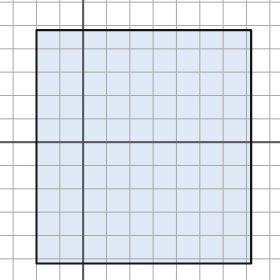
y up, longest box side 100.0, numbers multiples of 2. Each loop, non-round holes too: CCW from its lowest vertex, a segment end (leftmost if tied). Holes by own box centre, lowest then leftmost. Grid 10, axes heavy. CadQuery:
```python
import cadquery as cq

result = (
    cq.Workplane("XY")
    .moveTo(-20.0, -52.0)
    .lineTo(72.0, -52.0)
    .lineTo(72.0, 48.0)
    .lineTo(-20.0, 48.0)
    .close()
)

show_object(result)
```